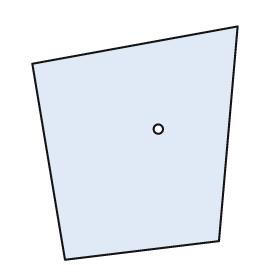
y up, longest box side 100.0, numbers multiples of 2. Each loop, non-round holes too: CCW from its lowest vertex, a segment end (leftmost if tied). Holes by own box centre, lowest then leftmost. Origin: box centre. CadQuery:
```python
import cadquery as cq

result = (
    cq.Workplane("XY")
    .moveTo(-30.0, -50.0)
    .lineTo(36.0, -42.0)
    .lineTo(44.0, 50.0)
    .lineTo(-44.0, 34.0)
    .close()
    .moveTo(10.0, 6.0)
    .circle(2.0)
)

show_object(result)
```